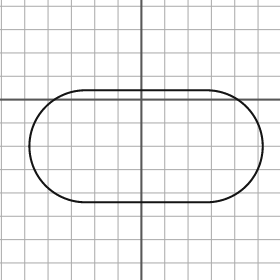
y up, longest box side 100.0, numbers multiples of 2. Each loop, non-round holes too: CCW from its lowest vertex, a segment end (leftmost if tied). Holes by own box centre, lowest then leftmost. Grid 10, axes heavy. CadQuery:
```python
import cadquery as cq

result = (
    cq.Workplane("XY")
    .moveTo(-24.0, -44.0)
    .lineTo(28.0, -44.0)
    .threePointArc((52.0, -20.0), (28.0, 4.0))
    .lineTo(-24.0, 4.0)
    .threePointArc((-48.0, -20.0), (-24.0, -44.0))
    .close()
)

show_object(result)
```